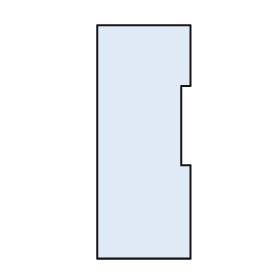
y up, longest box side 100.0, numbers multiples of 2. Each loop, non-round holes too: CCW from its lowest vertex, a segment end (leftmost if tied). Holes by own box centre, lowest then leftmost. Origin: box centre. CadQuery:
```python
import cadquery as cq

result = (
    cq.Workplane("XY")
    .moveTo(-20.0, -50.0)
    .lineTo(20.0, -50.0)
    .lineTo(20.0, -10.0)
    .lineTo(16.0, -10.0)
    .lineTo(16.0, 24.0)
    .lineTo(20.0, 24.0)
    .lineTo(20.0, 50.0)
    .lineTo(-20.0, 50.0)
    .close()
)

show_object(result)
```